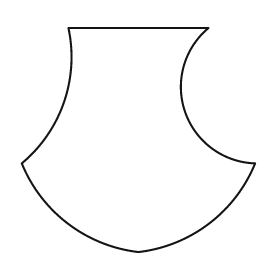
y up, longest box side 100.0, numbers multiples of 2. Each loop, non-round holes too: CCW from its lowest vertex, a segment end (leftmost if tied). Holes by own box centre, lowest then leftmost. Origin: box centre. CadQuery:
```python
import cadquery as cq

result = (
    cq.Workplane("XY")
    .moveTo(0.0, -48.0)
    .threePointArc((30.0, -36.0), (50.0, -10.0))
    .threePointArc((20.0, 12.0), (30.0, 48.0))
    .lineTo(-30.0, 48.0)
    .threePointArc((-32.0, 16.0), (-50.0, -10.0))
    .threePointArc((-30.0, -36.0), (0.0, -48.0))
    .close()
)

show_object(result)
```